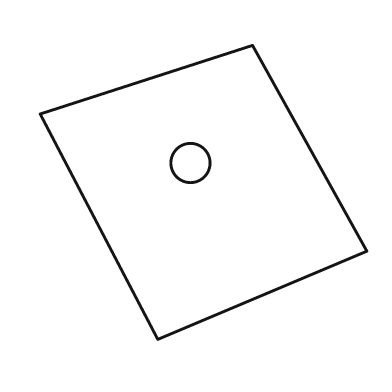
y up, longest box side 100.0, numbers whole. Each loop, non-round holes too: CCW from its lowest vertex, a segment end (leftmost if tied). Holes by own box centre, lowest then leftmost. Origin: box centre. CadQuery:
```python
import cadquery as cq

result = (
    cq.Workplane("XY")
    .moveTo(-14.0, -45.0)
    .lineTo(50.0, -18.0)
    .lineTo(15.0, 45.0)
    .lineTo(-50.0, 24.0)
    .close()
    .moveTo(-4.0, 9.0)
    .circle(6.0)
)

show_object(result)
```